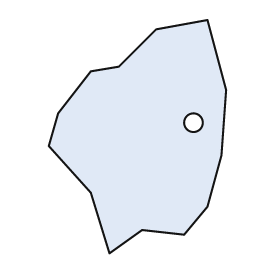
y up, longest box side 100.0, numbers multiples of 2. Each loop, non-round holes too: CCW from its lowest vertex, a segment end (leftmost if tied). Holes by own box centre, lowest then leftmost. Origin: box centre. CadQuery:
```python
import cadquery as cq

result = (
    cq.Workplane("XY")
    .moveTo(-12.0, -50.0)
    .lineTo(2.0, -40.0)
    .lineTo(20.0, -42.0)
    .lineTo(30.0, -30.0)
    .lineTo(36.0, -8.0)
    .lineTo(38.0, 20.0)
    .lineTo(30.0, 50.0)
    .lineTo(8.0, 46.0)
    .lineTo(-8.0, 30.0)
    .lineTo(-20.0, 28.0)
    .lineTo(-34.0, 10.0)
    .lineTo(-38.0, -4.0)
    .lineTo(-20.0, -24.0)
    .close()
    .moveTo(24.0, 6.0)
    .circle(4.0)
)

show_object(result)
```